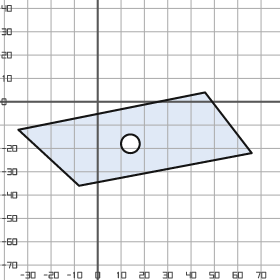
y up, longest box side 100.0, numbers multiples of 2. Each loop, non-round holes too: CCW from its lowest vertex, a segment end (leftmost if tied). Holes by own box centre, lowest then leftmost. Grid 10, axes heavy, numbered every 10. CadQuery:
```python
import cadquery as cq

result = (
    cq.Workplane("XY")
    .moveTo(-8.0, -36.0)
    .lineTo(66.0, -22.0)
    .lineTo(46.0, 4.0)
    .lineTo(-34.0, -12.0)
    .close()
    .moveTo(14.0, -18.0)
    .circle(4.0)
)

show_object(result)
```